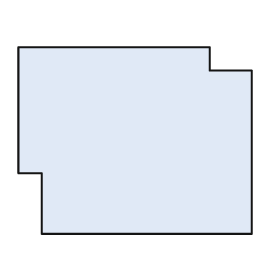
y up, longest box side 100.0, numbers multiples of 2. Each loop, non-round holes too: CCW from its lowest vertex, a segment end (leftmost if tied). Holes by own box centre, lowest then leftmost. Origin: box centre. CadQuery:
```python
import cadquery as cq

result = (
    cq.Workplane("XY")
    .moveTo(-40.0, -40.0)
    .lineTo(50.0, -40.0)
    .lineTo(50.0, 30.0)
    .lineTo(32.0, 30.0)
    .lineTo(32.0, 40.0)
    .lineTo(-50.0, 40.0)
    .lineTo(-50.0, -14.0)
    .lineTo(-40.0, -14.0)
    .close()
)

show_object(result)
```